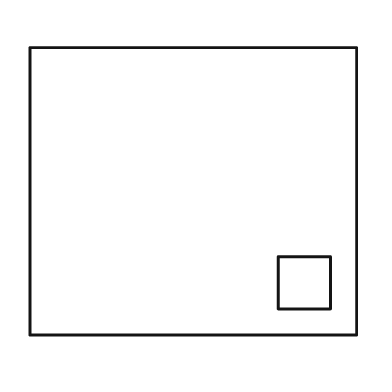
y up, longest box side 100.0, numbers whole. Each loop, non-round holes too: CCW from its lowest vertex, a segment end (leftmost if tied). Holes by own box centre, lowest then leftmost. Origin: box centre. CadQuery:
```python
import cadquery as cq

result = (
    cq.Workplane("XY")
    .moveTo(-50.0, -44.0)
    .lineTo(50.0, -44.0)
    .lineTo(50.0, 44.0)
    .lineTo(-50.0, 44.0)
    .close()
    .moveTo(26.0, -36.0)
    .lineTo(42.0, -36.0)
    .lineTo(42.0, -20.0)
    .lineTo(26.0, -20.0)
    .close()
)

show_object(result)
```